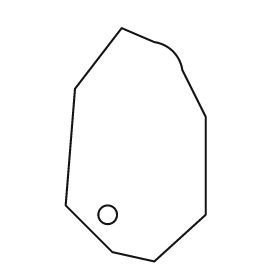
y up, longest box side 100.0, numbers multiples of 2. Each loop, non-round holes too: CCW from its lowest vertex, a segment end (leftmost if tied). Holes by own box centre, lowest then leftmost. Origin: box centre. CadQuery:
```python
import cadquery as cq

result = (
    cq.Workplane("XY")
    .moveTo(8.0, -50.0)
    .lineTo(30.0, -30.0)
    .lineTo(30.0, 12.0)
    .lineTo(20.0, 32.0)
    .threePointArc((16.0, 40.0), (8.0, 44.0))
    .lineTo(-6.0, 50.0)
    .lineTo(-26.0, 24.0)
    .lineTo(-30.0, -26.0)
    .lineTo(-10.0, -46.0)
    .close()
    .moveTo(-12.0, -30.0)
    .circle(4.0)
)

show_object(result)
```